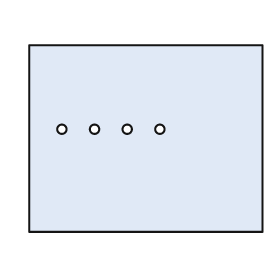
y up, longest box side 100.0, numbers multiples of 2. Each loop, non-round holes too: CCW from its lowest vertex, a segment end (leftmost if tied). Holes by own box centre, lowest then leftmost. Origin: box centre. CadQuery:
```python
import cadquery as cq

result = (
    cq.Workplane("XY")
    .moveTo(-50.0, -40.0)
    .lineTo(50.0, -40.0)
    .lineTo(50.0, 40.0)
    .lineTo(-50.0, 40.0)
    .close()
    .moveTo(-36.0, 4.0)
    .circle(2.0)
    .moveTo(-22.0, 4.0)
    .circle(2.0)
    .moveTo(-8.0, 4.0)
    .circle(2.0)
    .moveTo(6.0, 4.0)
    .circle(2.0)
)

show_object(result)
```